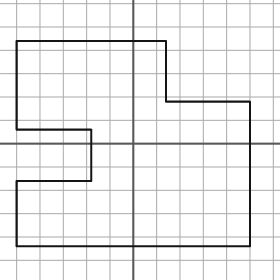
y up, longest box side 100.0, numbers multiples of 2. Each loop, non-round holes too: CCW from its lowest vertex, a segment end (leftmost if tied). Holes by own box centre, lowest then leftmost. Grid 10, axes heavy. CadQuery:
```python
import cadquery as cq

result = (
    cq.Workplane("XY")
    .moveTo(-50.0, -44.0)
    .lineTo(50.0, -44.0)
    .lineTo(50.0, 18.0)
    .lineTo(14.0, 18.0)
    .lineTo(14.0, 44.0)
    .lineTo(-50.0, 44.0)
    .lineTo(-50.0, 6.0)
    .lineTo(-18.0, 6.0)
    .lineTo(-18.0, -16.0)
    .lineTo(-50.0, -16.0)
    .close()
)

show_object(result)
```